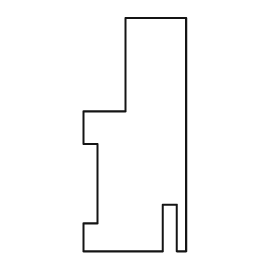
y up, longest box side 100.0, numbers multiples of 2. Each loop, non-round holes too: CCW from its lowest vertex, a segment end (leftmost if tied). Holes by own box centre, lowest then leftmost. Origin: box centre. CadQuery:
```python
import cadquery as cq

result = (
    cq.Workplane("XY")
    .moveTo(-22.0, -50.0)
    .lineTo(12.0, -50.0)
    .lineTo(12.0, -30.0)
    .lineTo(18.0, -30.0)
    .lineTo(18.0, -50.0)
    .lineTo(22.0, -50.0)
    .lineTo(22.0, 50.0)
    .lineTo(-4.0, 50.0)
    .lineTo(-4.0, 10.0)
    .lineTo(-22.0, 10.0)
    .lineTo(-22.0, -4.0)
    .lineTo(-16.0, -4.0)
    .lineTo(-16.0, -38.0)
    .lineTo(-22.0, -38.0)
    .close()
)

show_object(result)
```